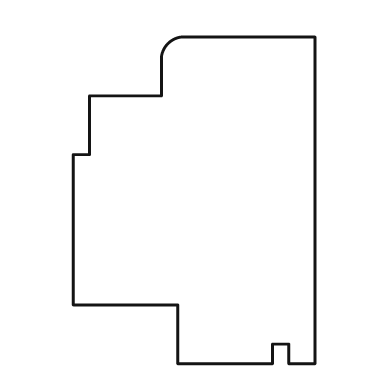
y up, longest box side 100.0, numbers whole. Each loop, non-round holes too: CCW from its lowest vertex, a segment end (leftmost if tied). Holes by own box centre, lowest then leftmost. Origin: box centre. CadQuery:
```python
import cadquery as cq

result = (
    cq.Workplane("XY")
    .moveTo(-5.0, -50.0)
    .lineTo(24.0, -50.0)
    .lineTo(24.0, -44.0)
    .lineTo(29.0, -44.0)
    .lineTo(29.0, -50.0)
    .lineTo(37.0, -50.0)
    .lineTo(37.0, 50.0)
    .lineTo(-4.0, 50.0)
    .threePointArc((-8.0, 48.0), (-10.0, 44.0))
    .lineTo(-10.0, 32.0)
    .lineTo(-32.0, 32.0)
    .lineTo(-32.0, 14.0)
    .lineTo(-37.0, 14.0)
    .lineTo(-37.0, -32.0)
    .lineTo(-5.0, -32.0)
    .close()
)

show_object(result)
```